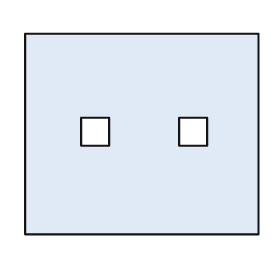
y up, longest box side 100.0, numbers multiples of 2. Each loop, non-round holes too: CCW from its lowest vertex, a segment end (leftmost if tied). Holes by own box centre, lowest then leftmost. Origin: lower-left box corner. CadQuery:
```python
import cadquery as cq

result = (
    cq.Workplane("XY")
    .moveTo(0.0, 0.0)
    .lineTo(100.0, 0.0)
    .lineTo(100.0, 86.0)
    .lineTo(0.0, 86.0)
    .close()
    .moveTo(24.0, 38.0)
    .lineTo(36.0, 38.0)
    .lineTo(36.0, 50.0)
    .lineTo(24.0, 50.0)
    .close()
    .moveTo(66.0, 38.0)
    .lineTo(78.0, 38.0)
    .lineTo(78.0, 50.0)
    .lineTo(66.0, 50.0)
    .close()
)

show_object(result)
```